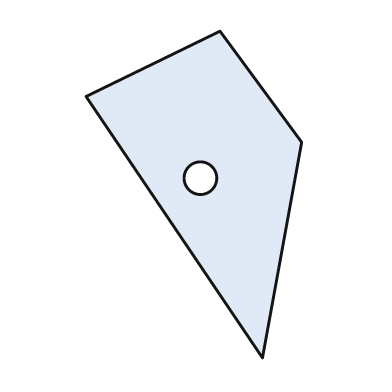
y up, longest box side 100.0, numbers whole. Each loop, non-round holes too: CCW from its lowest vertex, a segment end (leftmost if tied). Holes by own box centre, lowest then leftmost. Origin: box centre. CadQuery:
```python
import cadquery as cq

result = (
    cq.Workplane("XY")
    .moveTo(21.0, -50.0)
    .lineTo(33.0, 16.0)
    .lineTo(8.0, 50.0)
    .lineTo(-33.0, 30.0)
    .close()
    .moveTo(2.0, 5.0)
    .circle(5.0)
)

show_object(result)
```